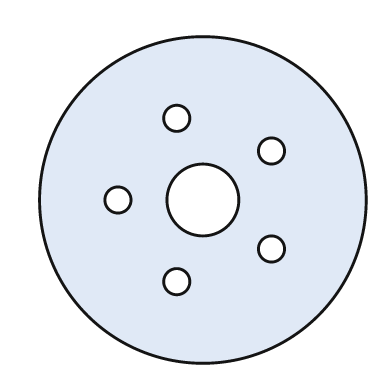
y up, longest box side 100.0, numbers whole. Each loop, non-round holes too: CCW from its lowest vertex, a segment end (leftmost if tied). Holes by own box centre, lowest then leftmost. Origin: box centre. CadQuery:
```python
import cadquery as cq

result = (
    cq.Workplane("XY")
    .moveTo(0.0, 0.0)
    .circle(50.0)
    .moveTo(-8.0, -25.0)
    .circle(4.0)
    .moveTo(21.0, -15.0)
    .circle(4.0)
    .moveTo(-26.0, 0.0)
    .circle(4.0)
    .moveTo(0.0, 0.0)
    .circle(11.0)
    .moveTo(21.0, 15.0)
    .circle(4.0)
    .moveTo(-8.0, 25.0)
    .circle(4.0)
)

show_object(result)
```